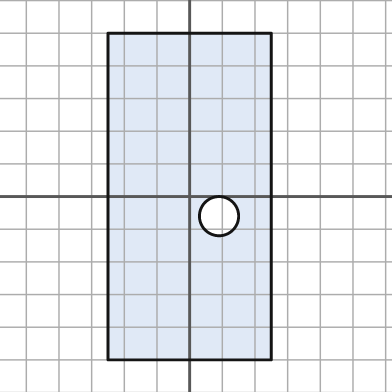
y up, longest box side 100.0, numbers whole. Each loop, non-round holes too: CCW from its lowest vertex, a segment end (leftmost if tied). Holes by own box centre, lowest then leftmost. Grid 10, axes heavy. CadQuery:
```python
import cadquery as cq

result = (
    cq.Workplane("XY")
    .moveTo(-25.0, -50.0)
    .lineTo(25.0, -50.0)
    .lineTo(25.0, 50.0)
    .lineTo(-25.0, 50.0)
    .close()
    .moveTo(9.0, -6.0)
    .circle(6.0)
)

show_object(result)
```